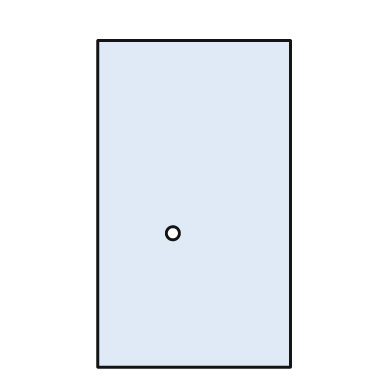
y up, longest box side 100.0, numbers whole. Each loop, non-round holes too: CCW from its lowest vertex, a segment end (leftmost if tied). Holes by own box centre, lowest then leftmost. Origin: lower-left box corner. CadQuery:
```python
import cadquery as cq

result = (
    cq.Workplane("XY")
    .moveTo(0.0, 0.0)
    .lineTo(59.0, 0.0)
    .lineTo(59.0, 100.0)
    .lineTo(0.0, 100.0)
    .close()
    .moveTo(23.0, 41.0)
    .circle(2.0)
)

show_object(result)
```